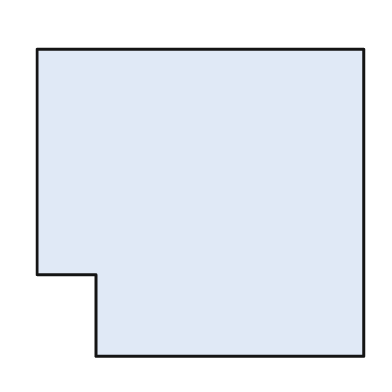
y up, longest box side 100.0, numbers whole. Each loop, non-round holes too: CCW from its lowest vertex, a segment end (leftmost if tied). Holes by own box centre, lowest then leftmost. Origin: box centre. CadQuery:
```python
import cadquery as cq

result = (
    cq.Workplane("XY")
    .moveTo(-32.0, -47.0)
    .lineTo(50.0, -47.0)
    .lineTo(50.0, 47.0)
    .lineTo(-50.0, 47.0)
    .lineTo(-50.0, -22.0)
    .lineTo(-32.0, -22.0)
    .close()
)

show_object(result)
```